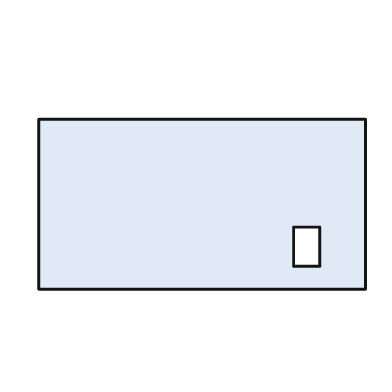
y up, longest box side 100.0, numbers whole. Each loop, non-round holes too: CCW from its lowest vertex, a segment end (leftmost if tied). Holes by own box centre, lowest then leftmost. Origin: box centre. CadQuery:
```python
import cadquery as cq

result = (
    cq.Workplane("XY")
    .moveTo(-50.0, -26.0)
    .lineTo(50.0, -26.0)
    .lineTo(50.0, 26.0)
    .lineTo(-50.0, 26.0)
    .close()
    .moveTo(28.0, -19.0)
    .lineTo(36.0, -19.0)
    .lineTo(36.0, -7.0)
    .lineTo(28.0, -7.0)
    .close()
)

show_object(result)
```